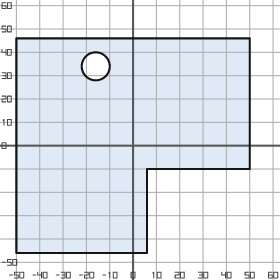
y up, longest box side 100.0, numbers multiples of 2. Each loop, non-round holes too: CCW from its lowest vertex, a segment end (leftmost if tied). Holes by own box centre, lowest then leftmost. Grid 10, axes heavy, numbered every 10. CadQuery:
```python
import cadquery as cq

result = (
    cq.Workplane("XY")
    .moveTo(-50.0, -46.0)
    .lineTo(6.0, -46.0)
    .lineTo(6.0, -10.0)
    .lineTo(50.0, -10.0)
    .lineTo(50.0, 46.0)
    .lineTo(-50.0, 46.0)
    .close()
    .moveTo(-16.0, 34.0)
    .circle(6.0)
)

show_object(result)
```